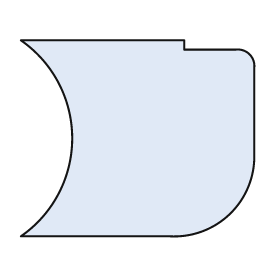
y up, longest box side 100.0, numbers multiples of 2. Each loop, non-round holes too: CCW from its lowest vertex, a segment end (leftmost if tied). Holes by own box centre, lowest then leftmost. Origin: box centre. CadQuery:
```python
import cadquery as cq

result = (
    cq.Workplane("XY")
    .moveTo(-50.0, -42.0)
    .lineTo(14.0, -42.0)
    .threePointArc((40.0, -32.0), (50.0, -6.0))
    .lineTo(50.0, 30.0)
    .threePointArc((48.0, 36.0), (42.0, 38.0))
    .lineTo(20.0, 38.0)
    .lineTo(20.0, 42.0)
    .lineTo(-50.0, 42.0)
    .threePointArc((-28.0, 0.0), (-50.0, -42.0))
    .close()
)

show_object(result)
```